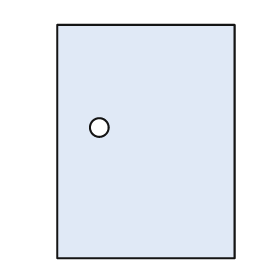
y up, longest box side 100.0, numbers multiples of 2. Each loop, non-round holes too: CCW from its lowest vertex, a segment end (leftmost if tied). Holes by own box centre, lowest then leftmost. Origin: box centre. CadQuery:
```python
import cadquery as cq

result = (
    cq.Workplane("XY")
    .moveTo(-38.0, -50.0)
    .lineTo(38.0, -50.0)
    .lineTo(38.0, 50.0)
    .lineTo(-38.0, 50.0)
    .close()
    .moveTo(-20.0, 6.0)
    .circle(4.0)
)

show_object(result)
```